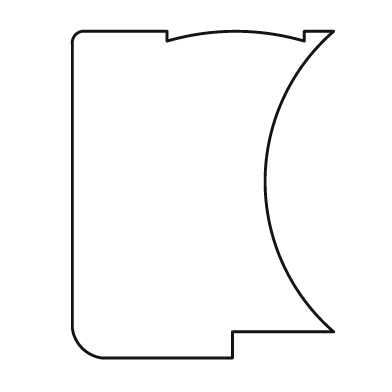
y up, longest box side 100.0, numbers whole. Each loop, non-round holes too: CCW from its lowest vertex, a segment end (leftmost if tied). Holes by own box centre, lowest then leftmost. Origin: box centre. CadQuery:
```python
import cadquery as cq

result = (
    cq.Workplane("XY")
    .moveTo(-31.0, -50.0)
    .lineTo(9.0, -50.0)
    .lineTo(9.0, -42.0)
    .lineTo(40.0, -42.0)
    .threePointArc((19.0, 4.0), (40.0, 50.0))
    .lineTo(31.0, 50.0)
    .lineTo(31.0, 47.0)
    .threePointArc((10.0, 50.0), (-11.0, 47.0))
    .lineTo(-11.0, 50.0)
    .lineTo(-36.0, 50.0)
    .threePointArc((-39.0, 49.0), (-40.0, 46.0))
    .lineTo(-40.0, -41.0)
    .threePointArc((-37.0, -47.0), (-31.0, -50.0))
    .close()
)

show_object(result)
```